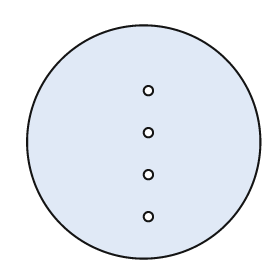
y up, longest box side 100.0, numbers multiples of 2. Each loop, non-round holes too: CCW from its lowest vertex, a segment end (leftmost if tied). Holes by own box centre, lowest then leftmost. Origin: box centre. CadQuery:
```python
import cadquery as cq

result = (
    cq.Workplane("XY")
    .moveTo(0.0, 0.0)
    .circle(50.0)
    .moveTo(2.0, -32.0)
    .circle(2.0)
    .moveTo(2.0, -14.0)
    .circle(2.0)
    .moveTo(2.0, 4.0)
    .circle(2.0)
    .moveTo(2.0, 22.0)
    .circle(2.0)
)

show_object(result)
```